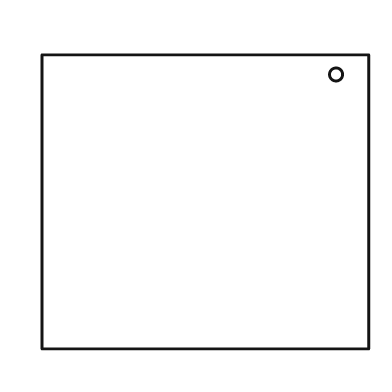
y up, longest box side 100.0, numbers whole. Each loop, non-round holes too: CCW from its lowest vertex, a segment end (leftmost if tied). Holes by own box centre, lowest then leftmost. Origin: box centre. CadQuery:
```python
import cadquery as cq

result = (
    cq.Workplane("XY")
    .moveTo(-50.0, -45.0)
    .lineTo(50.0, -45.0)
    .lineTo(50.0, 45.0)
    .lineTo(-50.0, 45.0)
    .close()
    .moveTo(40.0, 39.0)
    .circle(2.0)
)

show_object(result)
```